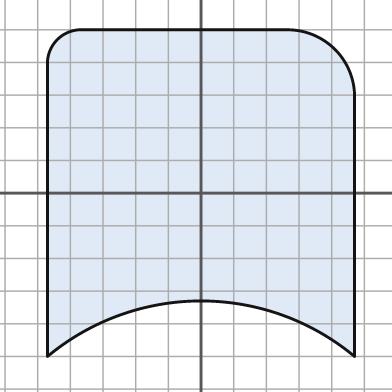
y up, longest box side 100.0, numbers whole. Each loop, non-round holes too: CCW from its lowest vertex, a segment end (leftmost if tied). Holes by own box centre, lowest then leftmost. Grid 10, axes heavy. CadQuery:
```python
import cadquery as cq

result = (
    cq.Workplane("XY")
    .moveTo(-47.0, -50.0)
    .threePointArc((0.0, -33.0), (47.0, -50.0))
    .lineTo(47.0, 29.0)
    .threePointArc((41.0, 44.0), (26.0, 50.0))
    .lineTo(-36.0, 50.0)
    .threePointArc((-44.0, 47.0), (-47.0, 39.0))
    .close()
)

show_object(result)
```